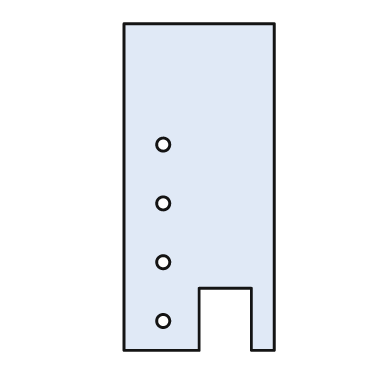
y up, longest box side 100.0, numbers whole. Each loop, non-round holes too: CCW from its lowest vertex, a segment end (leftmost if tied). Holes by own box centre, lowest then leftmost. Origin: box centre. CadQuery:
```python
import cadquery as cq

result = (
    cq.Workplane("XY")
    .moveTo(-23.0, -50.0)
    .lineTo(0.0, -50.0)
    .lineTo(0.0, -31.0)
    .lineTo(16.0, -31.0)
    .lineTo(16.0, -50.0)
    .lineTo(23.0, -50.0)
    .lineTo(23.0, 50.0)
    .lineTo(-23.0, 50.0)
    .close()
    .moveTo(-11.0, -41.0)
    .circle(2.0)
    .moveTo(-11.0, -23.0)
    .circle(2.0)
    .moveTo(-11.0, -5.0)
    .circle(2.0)
    .moveTo(-11.0, 13.0)
    .circle(2.0)
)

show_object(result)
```